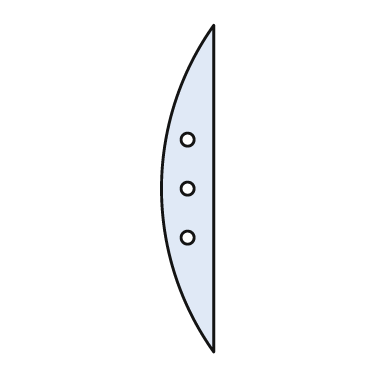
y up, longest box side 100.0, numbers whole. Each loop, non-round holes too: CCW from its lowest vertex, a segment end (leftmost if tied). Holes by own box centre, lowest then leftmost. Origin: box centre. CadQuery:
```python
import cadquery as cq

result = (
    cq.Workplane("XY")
    .moveTo(8.0, -50.0)
    .lineTo(8.0, 50.0)
    .threePointArc((-8.0, 0.0), (8.0, -50.0))
    .close()
    .moveTo(0.0, -15.0)
    .circle(2.0)
    .moveTo(0.0, 0.0)
    .circle(2.0)
    .moveTo(0.0, 15.0)
    .circle(2.0)
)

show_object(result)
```